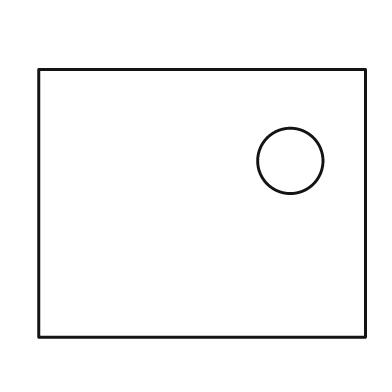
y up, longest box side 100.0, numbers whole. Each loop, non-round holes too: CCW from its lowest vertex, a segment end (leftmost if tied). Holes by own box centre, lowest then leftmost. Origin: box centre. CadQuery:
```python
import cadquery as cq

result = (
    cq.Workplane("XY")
    .moveTo(-50.0, -41.0)
    .lineTo(50.0, -41.0)
    .lineTo(50.0, 41.0)
    .lineTo(-50.0, 41.0)
    .close()
    .moveTo(27.0, 13.0)
    .circle(10.0)
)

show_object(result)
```